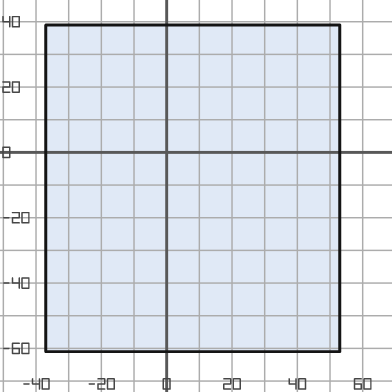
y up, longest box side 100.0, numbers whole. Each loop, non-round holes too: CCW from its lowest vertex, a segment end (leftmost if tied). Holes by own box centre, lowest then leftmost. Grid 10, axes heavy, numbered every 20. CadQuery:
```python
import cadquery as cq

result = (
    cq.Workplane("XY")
    .moveTo(-37.0, -61.0)
    .lineTo(53.0, -61.0)
    .lineTo(53.0, 39.0)
    .lineTo(-37.0, 39.0)
    .close()
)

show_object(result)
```